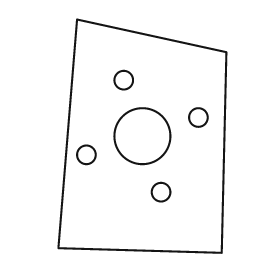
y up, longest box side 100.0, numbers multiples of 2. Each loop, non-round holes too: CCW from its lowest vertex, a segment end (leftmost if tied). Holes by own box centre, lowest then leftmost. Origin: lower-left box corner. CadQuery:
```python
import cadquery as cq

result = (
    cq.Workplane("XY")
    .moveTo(70.0, 0.0)
    .lineTo(72.0, 86.0)
    .lineTo(8.0, 100.0)
    .lineTo(0.0, 2.0)
    .close()
    .moveTo(44.0, 26.0)
    .circle(4.0)
    .moveTo(12.0, 42.0)
    .circle(4.0)
    .moveTo(36.0, 50.0)
    .circle(12.0)
    .moveTo(60.0, 58.0)
    .circle(4.0)
    .moveTo(28.0, 74.0)
    .circle(4.0)
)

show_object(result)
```